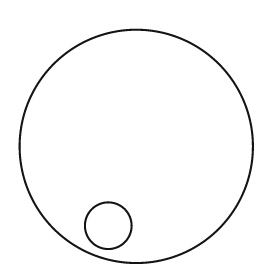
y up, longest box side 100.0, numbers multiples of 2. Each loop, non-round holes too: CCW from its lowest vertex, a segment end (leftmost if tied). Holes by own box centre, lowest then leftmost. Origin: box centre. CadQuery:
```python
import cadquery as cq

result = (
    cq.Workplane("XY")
    .moveTo(0.0, 0.0)
    .circle(50.0)
    .moveTo(-12.0, -34.0)
    .circle(10.0)
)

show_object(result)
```